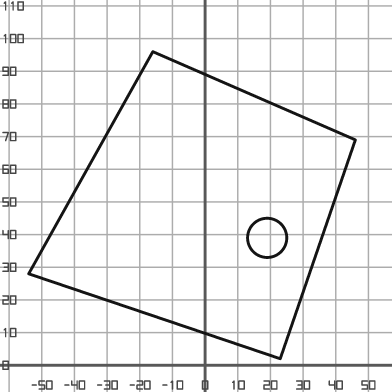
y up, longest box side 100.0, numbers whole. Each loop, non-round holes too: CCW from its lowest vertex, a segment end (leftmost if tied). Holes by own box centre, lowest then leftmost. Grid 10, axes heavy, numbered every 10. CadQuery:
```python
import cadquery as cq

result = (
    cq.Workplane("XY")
    .moveTo(23.0, 2.0)
    .lineTo(46.0, 69.0)
    .lineTo(-16.0, 96.0)
    .lineTo(-54.0, 28.0)
    .close()
    .moveTo(19.0, 39.0)
    .circle(6.0)
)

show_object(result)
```